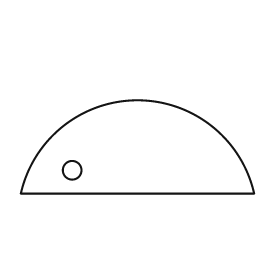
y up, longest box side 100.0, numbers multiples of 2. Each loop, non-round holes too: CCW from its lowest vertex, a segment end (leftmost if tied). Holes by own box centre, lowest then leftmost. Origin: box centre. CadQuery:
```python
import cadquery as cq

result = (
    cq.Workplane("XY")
    .moveTo(-50.0, -20.0)
    .lineTo(50.0, -20.0)
    .threePointArc((0.0, 20.0), (-50.0, -20.0))
    .close()
    .moveTo(-28.0, -10.0)
    .circle(4.0)
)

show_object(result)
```